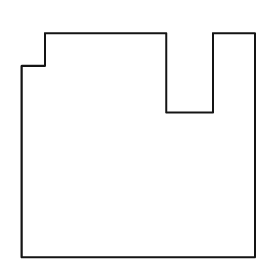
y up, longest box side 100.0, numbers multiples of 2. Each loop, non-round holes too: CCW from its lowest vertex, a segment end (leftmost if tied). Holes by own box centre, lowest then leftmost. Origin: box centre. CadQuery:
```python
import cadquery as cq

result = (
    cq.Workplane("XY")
    .moveTo(-50.0, -48.0)
    .lineTo(50.0, -48.0)
    .lineTo(50.0, 48.0)
    .lineTo(32.0, 48.0)
    .lineTo(32.0, 14.0)
    .lineTo(12.0, 14.0)
    .lineTo(12.0, 48.0)
    .lineTo(-40.0, 48.0)
    .lineTo(-40.0, 34.0)
    .lineTo(-50.0, 34.0)
    .close()
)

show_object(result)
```